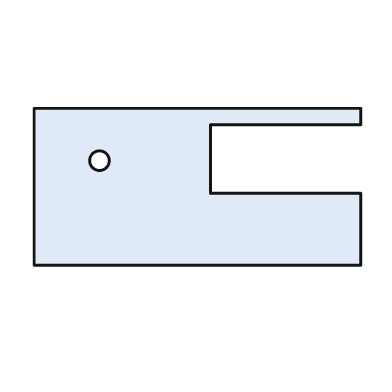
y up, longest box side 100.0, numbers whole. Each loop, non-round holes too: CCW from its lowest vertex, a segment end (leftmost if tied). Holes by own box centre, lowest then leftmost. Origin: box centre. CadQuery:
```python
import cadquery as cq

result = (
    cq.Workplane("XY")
    .moveTo(-50.0, -24.0)
    .lineTo(50.0, -24.0)
    .lineTo(50.0, -2.0)
    .lineTo(4.0, -2.0)
    .lineTo(4.0, 19.0)
    .lineTo(50.0, 19.0)
    .lineTo(50.0, 24.0)
    .lineTo(-50.0, 24.0)
    .close()
    .moveTo(-30.0, 8.0)
    .circle(3.0)
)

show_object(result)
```